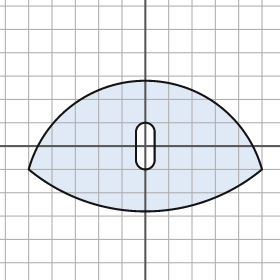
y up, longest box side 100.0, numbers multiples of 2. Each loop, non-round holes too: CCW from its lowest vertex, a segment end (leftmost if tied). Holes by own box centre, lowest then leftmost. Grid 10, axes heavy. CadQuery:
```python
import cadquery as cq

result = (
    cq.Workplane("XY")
    .moveTo(-50.0, -10.0)
    .threePointArc((0.0, -28.0), (50.0, -10.0))
    .threePointArc((0.0, 28.0), (-50.0, -10.0))
    .close()
    .moveTo(-4.0, -6.0)
    .threePointArc((0.0, -10.0), (4.0, -6.0))
    .lineTo(4.0, 6.0)
    .threePointArc((0.0, 10.0), (-4.0, 6.0))
    .close()
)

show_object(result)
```